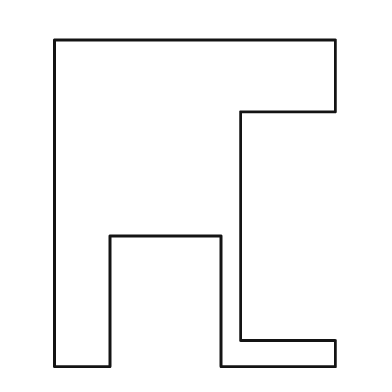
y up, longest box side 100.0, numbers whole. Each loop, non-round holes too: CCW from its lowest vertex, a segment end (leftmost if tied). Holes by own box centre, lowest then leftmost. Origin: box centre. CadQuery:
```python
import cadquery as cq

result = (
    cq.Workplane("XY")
    .moveTo(-43.0, -50.0)
    .lineTo(-26.0, -50.0)
    .lineTo(-26.0, -10.0)
    .lineTo(8.0, -10.0)
    .lineTo(8.0, -50.0)
    .lineTo(43.0, -50.0)
    .lineTo(43.0, -42.0)
    .lineTo(14.0, -42.0)
    .lineTo(14.0, 28.0)
    .lineTo(43.0, 28.0)
    .lineTo(43.0, 50.0)
    .lineTo(-43.0, 50.0)
    .close()
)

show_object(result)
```